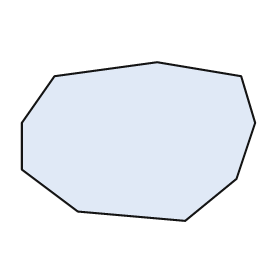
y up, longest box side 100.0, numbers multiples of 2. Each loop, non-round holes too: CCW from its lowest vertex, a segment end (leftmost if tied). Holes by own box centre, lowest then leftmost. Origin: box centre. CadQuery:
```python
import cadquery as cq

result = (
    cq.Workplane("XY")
    .moveTo(20.0, -34.0)
    .lineTo(42.0, -16.0)
    .lineTo(50.0, 8.0)
    .lineTo(44.0, 28.0)
    .lineTo(8.0, 34.0)
    .lineTo(-36.0, 28.0)
    .lineTo(-50.0, 8.0)
    .lineTo(-50.0, -12.0)
    .lineTo(-26.0, -30.0)
    .close()
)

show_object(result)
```